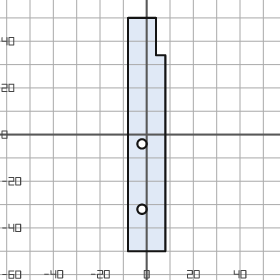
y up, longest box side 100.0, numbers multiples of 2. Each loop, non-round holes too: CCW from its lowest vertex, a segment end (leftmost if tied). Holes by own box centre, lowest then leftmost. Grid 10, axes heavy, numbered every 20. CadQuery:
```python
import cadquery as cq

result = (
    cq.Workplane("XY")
    .moveTo(-8.0, -50.0)
    .lineTo(8.0, -50.0)
    .lineTo(8.0, 34.0)
    .lineTo(4.0, 34.0)
    .lineTo(4.0, 50.0)
    .lineTo(-8.0, 50.0)
    .close()
    .moveTo(-2.0, -32.0)
    .circle(2.0)
    .moveTo(-2.0, -4.0)
    .circle(2.0)
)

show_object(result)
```